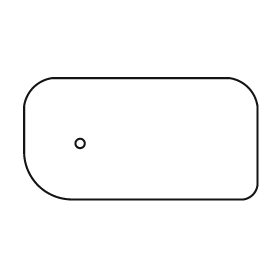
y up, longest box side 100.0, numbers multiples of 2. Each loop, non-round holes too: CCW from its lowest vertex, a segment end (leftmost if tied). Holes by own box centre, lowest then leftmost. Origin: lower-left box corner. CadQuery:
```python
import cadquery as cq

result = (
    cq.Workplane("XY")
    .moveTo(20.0, 0.0)
    .lineTo(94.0, 0.0)
    .threePointArc((98.0, 2.0), (100.0, 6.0))
    .lineTo(100.0, 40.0)
    .threePointArc((96.0, 48.0), (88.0, 52.0))
    .lineTo(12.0, 52.0)
    .threePointArc((4.0, 48.0), (0.0, 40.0))
    .lineTo(0.0, 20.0)
    .threePointArc((6.0, 6.0), (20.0, 0.0))
    .close()
    .moveTo(24.0, 24.0)
    .circle(2.0)
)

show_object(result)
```